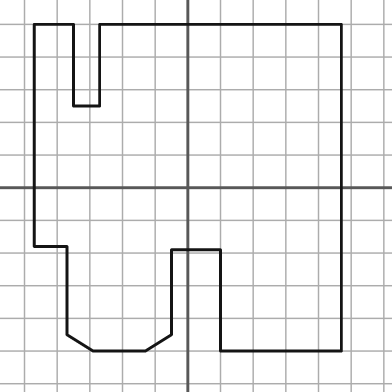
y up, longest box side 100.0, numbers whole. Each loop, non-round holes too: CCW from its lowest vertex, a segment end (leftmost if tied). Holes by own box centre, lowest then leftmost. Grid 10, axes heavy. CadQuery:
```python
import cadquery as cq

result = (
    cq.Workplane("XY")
    .moveTo(-29.0, -50.0)
    .lineTo(-13.0, -50.0)
    .lineTo(-5.0, -45.0)
    .lineTo(-5.0, -19.0)
    .lineTo(10.0, -19.0)
    .lineTo(10.0, -50.0)
    .lineTo(47.0, -50.0)
    .lineTo(47.0, 50.0)
    .lineTo(-27.0, 50.0)
    .lineTo(-27.0, 25.0)
    .lineTo(-35.0, 25.0)
    .lineTo(-35.0, 50.0)
    .lineTo(-47.0, 50.0)
    .lineTo(-47.0, -18.0)
    .lineTo(-37.0, -18.0)
    .lineTo(-37.0, -45.0)
    .close()
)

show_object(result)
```